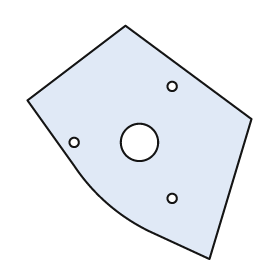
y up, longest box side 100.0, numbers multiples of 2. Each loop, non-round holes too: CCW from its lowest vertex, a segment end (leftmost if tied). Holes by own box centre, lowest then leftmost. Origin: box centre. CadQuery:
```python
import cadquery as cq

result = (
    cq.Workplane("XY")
    .moveTo(30.0, -50.0)
    .lineTo(48.0, 10.0)
    .lineTo(-6.0, 50.0)
    .lineTo(-48.0, 18.0)
    .lineTo(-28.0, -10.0)
    .threePointArc((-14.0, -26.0), (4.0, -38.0))
    .close()
    .moveTo(14.0, -24.0)
    .circle(2.0)
    .moveTo(-28.0, 0.0)
    .circle(2.0)
    .moveTo(0.0, 0.0)
    .circle(8.0)
    .moveTo(14.0, 24.0)
    .circle(2.0)
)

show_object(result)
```